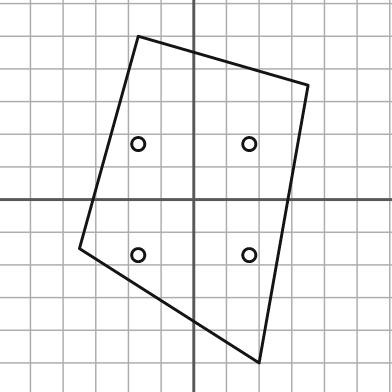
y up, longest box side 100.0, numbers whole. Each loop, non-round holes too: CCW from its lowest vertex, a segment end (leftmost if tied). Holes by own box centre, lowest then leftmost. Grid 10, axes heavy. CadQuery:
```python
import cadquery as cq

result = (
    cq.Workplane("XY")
    .moveTo(20.0, -50.0)
    .lineTo(35.0, 35.0)
    .lineTo(-17.0, 50.0)
    .lineTo(-35.0, -15.0)
    .close()
    .moveTo(-17.0, -17.0)
    .circle(2.0)
    .moveTo(17.0, -17.0)
    .circle(2.0)
    .moveTo(-17.0, 17.0)
    .circle(2.0)
    .moveTo(17.0, 17.0)
    .circle(2.0)
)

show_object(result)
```